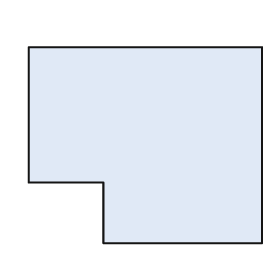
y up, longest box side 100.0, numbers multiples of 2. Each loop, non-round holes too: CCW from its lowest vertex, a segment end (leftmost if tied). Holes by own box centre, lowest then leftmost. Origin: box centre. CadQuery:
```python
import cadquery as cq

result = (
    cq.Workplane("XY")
    .moveTo(-18.0, -42.0)
    .lineTo(50.0, -42.0)
    .lineTo(50.0, 42.0)
    .lineTo(-50.0, 42.0)
    .lineTo(-50.0, -16.0)
    .lineTo(-18.0, -16.0)
    .close()
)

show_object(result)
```